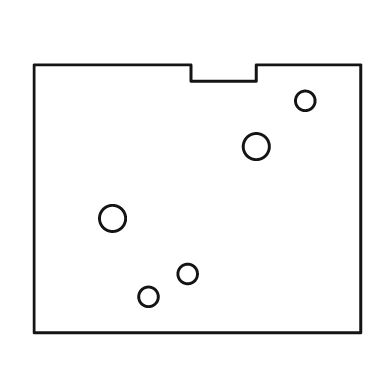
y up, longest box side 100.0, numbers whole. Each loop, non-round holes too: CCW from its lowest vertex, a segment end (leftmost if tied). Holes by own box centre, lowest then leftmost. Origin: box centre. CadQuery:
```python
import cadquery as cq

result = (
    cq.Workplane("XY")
    .moveTo(-50.0, -41.0)
    .lineTo(50.0, -41.0)
    .lineTo(50.0, 41.0)
    .lineTo(18.0, 41.0)
    .lineTo(18.0, 36.0)
    .lineTo(-2.0, 36.0)
    .lineTo(-2.0, 41.0)
    .lineTo(-50.0, 41.0)
    .close()
    .moveTo(-15.0, -30.0)
    .circle(3.0)
    .moveTo(-3.0, -23.0)
    .circle(3.0)
    .moveTo(-26.0, -6.0)
    .circle(4.0)
    .moveTo(18.0, 16.0)
    .circle(4.0)
    .moveTo(33.0, 30.0)
    .circle(3.0)
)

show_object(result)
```